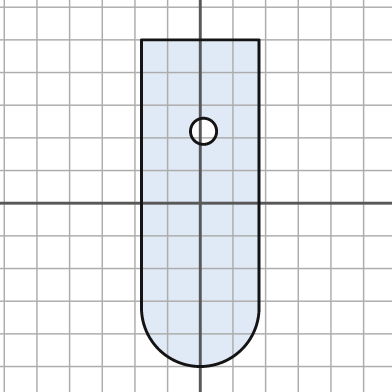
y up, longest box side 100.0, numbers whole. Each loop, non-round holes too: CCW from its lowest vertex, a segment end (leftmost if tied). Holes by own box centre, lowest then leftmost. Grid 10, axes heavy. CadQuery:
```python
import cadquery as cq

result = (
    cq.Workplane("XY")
    .moveTo(-18.0, -32.0)
    .threePointArc((0.0, -50.0), (18.0, -32.0))
    .lineTo(18.0, 50.0)
    .lineTo(-18.0, 50.0)
    .close()
    .moveTo(1.0, 22.0)
    .circle(4.0)
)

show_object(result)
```